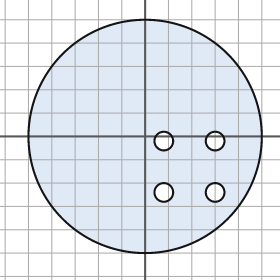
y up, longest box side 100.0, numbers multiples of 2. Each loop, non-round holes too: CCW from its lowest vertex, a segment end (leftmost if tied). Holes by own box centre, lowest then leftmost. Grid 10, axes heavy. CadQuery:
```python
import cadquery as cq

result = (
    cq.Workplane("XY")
    .moveTo(0.0, 0.0)
    .circle(50.0)
    .moveTo(8.0, -24.0)
    .circle(4.0)
    .moveTo(30.0, -24.0)
    .circle(4.0)
    .moveTo(8.0, -2.0)
    .circle(4.0)
    .moveTo(30.0, -2.0)
    .circle(4.0)
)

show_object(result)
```